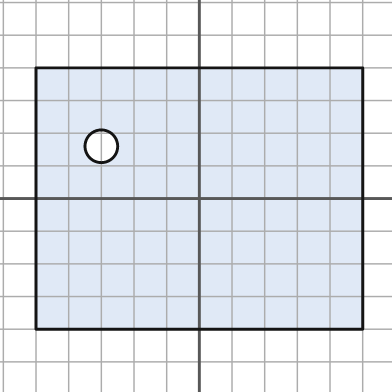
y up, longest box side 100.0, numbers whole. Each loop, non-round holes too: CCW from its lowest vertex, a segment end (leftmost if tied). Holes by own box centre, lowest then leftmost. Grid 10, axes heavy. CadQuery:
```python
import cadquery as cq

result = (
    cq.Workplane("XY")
    .moveTo(-50.0, -40.0)
    .lineTo(50.0, -40.0)
    .lineTo(50.0, 40.0)
    .lineTo(-50.0, 40.0)
    .close()
    .moveTo(-30.0, 16.0)
    .circle(5.0)
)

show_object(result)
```